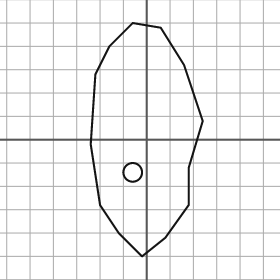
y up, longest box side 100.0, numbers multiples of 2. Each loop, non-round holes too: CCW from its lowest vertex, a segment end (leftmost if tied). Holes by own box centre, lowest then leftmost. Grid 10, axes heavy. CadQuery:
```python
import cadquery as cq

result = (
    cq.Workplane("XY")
    .moveTo(-2.0, -50.0)
    .lineTo(8.0, -42.0)
    .lineTo(18.0, -28.0)
    .lineTo(18.0, -12.0)
    .lineTo(24.0, 8.0)
    .lineTo(16.0, 32.0)
    .lineTo(6.0, 48.0)
    .lineTo(-6.0, 50.0)
    .lineTo(-16.0, 40.0)
    .lineTo(-22.0, 28.0)
    .lineTo(-24.0, -2.0)
    .lineTo(-20.0, -28.0)
    .lineTo(-12.0, -40.0)
    .close()
    .moveTo(-6.0, -14.0)
    .circle(4.0)
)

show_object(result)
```